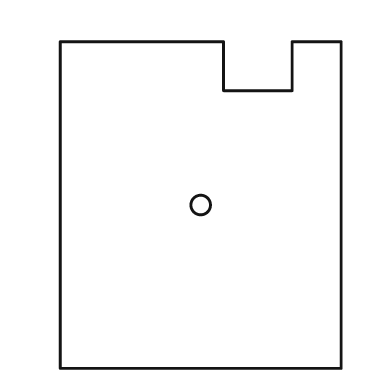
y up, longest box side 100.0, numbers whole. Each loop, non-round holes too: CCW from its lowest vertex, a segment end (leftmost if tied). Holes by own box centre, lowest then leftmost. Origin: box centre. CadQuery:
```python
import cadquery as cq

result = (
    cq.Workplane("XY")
    .moveTo(-43.0, -50.0)
    .lineTo(43.0, -50.0)
    .lineTo(43.0, 50.0)
    .lineTo(28.0, 50.0)
    .lineTo(28.0, 35.0)
    .lineTo(7.0, 35.0)
    .lineTo(7.0, 50.0)
    .lineTo(-43.0, 50.0)
    .close()
    .moveTo(0.0, 0.0)
    .circle(3.0)
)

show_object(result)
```